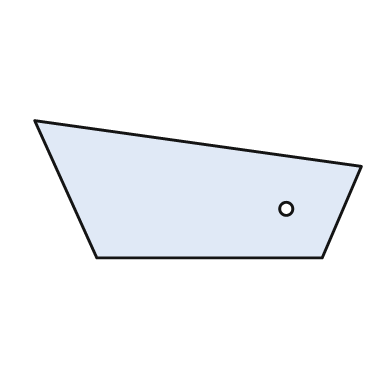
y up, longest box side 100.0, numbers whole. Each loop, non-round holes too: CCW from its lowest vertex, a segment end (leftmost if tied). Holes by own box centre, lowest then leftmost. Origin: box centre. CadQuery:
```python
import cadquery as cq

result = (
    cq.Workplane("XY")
    .moveTo(-31.0, -21.0)
    .lineTo(38.0, -21.0)
    .lineTo(50.0, 7.0)
    .lineTo(-50.0, 21.0)
    .close()
    .moveTo(27.0, -6.0)
    .circle(2.0)
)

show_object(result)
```